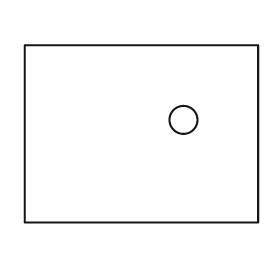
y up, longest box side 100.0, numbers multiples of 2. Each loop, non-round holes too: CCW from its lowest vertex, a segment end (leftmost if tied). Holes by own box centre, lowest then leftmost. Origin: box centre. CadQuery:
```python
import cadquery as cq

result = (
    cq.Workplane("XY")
    .moveTo(-50.0, -38.0)
    .lineTo(50.0, -38.0)
    .lineTo(50.0, 38.0)
    .lineTo(-50.0, 38.0)
    .close()
    .moveTo(18.0, 6.0)
    .circle(6.0)
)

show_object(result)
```